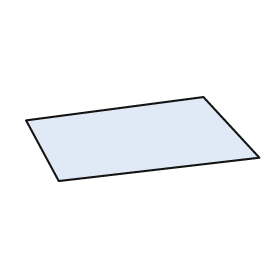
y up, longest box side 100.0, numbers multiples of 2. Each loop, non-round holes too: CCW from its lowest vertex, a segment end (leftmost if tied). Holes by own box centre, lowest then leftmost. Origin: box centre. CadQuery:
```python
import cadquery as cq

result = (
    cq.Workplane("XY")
    .moveTo(-36.0, -18.0)
    .lineTo(50.0, -8.0)
    .lineTo(26.0, 18.0)
    .lineTo(-50.0, 8.0)
    .close()
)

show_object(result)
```